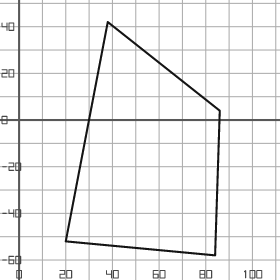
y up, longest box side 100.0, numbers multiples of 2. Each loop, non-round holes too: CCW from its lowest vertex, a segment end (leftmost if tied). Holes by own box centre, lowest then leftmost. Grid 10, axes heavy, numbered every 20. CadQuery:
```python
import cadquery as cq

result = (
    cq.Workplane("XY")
    .moveTo(84.0, -58.0)
    .lineTo(86.0, 4.0)
    .lineTo(38.0, 42.0)
    .lineTo(20.0, -52.0)
    .close()
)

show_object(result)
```